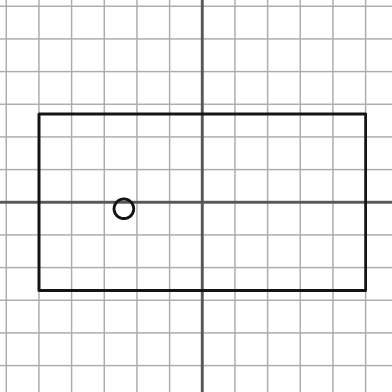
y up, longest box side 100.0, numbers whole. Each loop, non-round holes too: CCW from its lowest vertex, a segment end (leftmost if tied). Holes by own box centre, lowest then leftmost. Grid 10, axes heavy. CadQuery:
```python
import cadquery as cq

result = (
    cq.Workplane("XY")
    .moveTo(-50.0, -27.0)
    .lineTo(50.0, -27.0)
    .lineTo(50.0, 27.0)
    .lineTo(-50.0, 27.0)
    .close()
    .moveTo(-24.0, -2.0)
    .circle(3.0)
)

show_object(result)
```